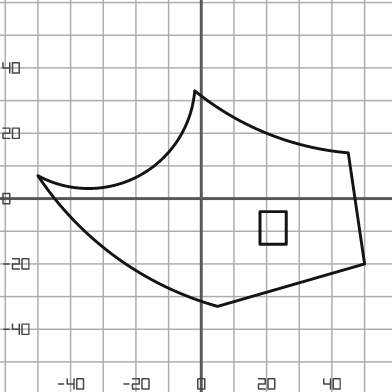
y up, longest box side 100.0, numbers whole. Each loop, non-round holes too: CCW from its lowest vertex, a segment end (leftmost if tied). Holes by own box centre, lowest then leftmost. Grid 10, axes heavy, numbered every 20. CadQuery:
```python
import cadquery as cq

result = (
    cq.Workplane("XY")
    .moveTo(5.0, -33.0)
    .lineTo(50.0, -20.0)
    .lineTo(45.0, 14.0)
    .threePointArc((20.0, 20.0), (-2.0, 33.0))
    .threePointArc((-19.0, 7.0), (-50.0, 7.0))
    .threePointArc((-26.0, -18.0), (5.0, -33.0))
    .close()
    .moveTo(18.0, -14.0)
    .lineTo(26.0, -14.0)
    .lineTo(26.0, -4.0)
    .lineTo(18.0, -4.0)
    .close()
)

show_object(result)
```